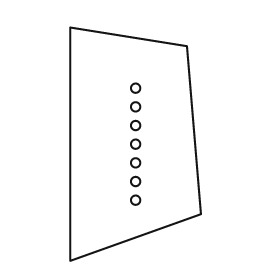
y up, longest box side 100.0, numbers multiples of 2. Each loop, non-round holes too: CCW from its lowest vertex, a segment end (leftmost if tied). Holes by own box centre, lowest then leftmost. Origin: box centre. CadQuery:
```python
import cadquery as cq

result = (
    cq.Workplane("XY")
    .moveTo(-28.0, -50.0)
    .lineTo(28.0, -30.0)
    .lineTo(22.0, 42.0)
    .lineTo(-28.0, 50.0)
    .close()
    .moveTo(0.0, -24.0)
    .circle(2.0)
    .moveTo(0.0, -16.0)
    .circle(2.0)
    .moveTo(0.0, -8.0)
    .circle(2.0)
    .moveTo(0.0, 0.0)
    .circle(2.0)
    .moveTo(0.0, 8.0)
    .circle(2.0)
    .moveTo(0.0, 16.0)
    .circle(2.0)
    .moveTo(0.0, 24.0)
    .circle(2.0)
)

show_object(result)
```